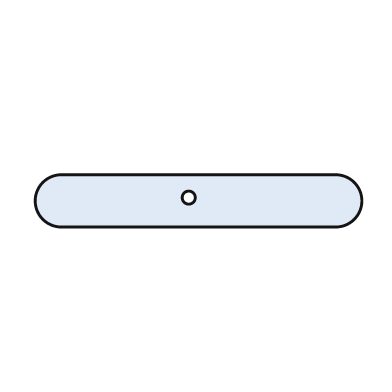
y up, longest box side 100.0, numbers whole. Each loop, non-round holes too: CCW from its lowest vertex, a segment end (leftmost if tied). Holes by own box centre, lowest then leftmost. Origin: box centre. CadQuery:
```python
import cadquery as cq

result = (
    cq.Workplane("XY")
    .moveTo(-42.0, -8.0)
    .lineTo(42.0, -8.0)
    .threePointArc((50.0, 0.0), (42.0, 8.0))
    .lineTo(-42.0, 8.0)
    .threePointArc((-50.0, 0.0), (-42.0, -8.0))
    .close()
    .moveTo(-3.0, 1.0)
    .circle(2.0)
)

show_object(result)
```